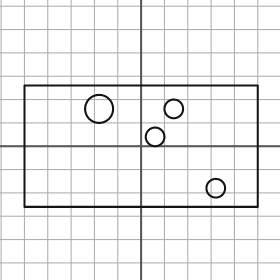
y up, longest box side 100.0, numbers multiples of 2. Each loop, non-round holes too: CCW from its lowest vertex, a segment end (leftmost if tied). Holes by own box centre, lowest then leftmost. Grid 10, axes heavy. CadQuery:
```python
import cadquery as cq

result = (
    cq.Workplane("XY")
    .moveTo(-50.0, -26.0)
    .lineTo(50.0, -26.0)
    .lineTo(50.0, 26.0)
    .lineTo(-50.0, 26.0)
    .close()
    .moveTo(32.0, -18.0)
    .circle(4.0)
    .moveTo(6.0, 4.0)
    .circle(4.0)
    .moveTo(-18.0, 16.0)
    .circle(6.0)
    .moveTo(14.0, 16.0)
    .circle(4.0)
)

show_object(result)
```